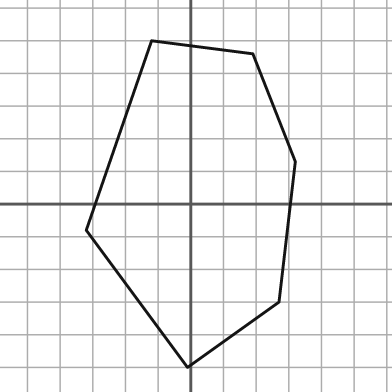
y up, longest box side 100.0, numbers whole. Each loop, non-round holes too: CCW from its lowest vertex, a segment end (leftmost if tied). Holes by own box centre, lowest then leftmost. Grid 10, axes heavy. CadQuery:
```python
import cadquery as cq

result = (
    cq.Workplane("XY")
    .moveTo(-1.0, -50.0)
    .lineTo(27.0, -30.0)
    .lineTo(32.0, 13.0)
    .lineTo(19.0, 46.0)
    .lineTo(-12.0, 50.0)
    .lineTo(-32.0, -8.0)
    .close()
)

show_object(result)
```